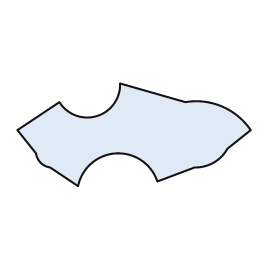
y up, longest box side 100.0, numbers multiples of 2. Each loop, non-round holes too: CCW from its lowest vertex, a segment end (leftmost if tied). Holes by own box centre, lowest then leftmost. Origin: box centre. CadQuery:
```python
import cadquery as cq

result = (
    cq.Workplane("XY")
    .moveTo(-24.0, -22.0)
    .threePointArc((-8.0, -8.0), (10.0, -20.0))
    .lineTo(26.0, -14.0)
    .threePointArc((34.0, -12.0), (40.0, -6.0))
    .lineTo(50.0, 2.0)
    .threePointArc((38.0, 12.0), (22.0, 14.0))
    .lineTo(-6.0, 22.0)
    .threePointArc((-16.0, 8.0), (-32.0, 14.0))
    .lineTo(-50.0, 2.0)
    .lineTo(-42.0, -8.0)
    .threePointArc((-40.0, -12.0), (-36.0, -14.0))
    .close()
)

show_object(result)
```